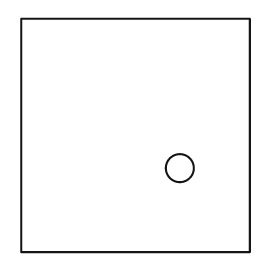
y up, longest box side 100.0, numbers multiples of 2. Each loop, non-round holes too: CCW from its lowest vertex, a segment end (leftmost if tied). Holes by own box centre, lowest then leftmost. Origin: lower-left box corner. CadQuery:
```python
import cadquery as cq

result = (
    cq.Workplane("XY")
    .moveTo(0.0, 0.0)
    .lineTo(98.0, 0.0)
    .lineTo(98.0, 100.0)
    .lineTo(0.0, 100.0)
    .close()
    .moveTo(68.0, 36.0)
    .circle(6.0)
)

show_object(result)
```